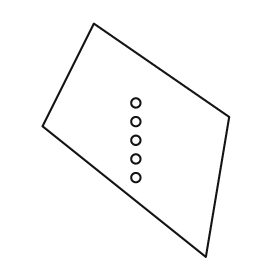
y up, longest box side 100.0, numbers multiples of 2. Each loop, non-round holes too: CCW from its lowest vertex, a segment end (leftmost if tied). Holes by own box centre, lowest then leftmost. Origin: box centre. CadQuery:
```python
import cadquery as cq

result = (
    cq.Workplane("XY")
    .moveTo(30.0, -50.0)
    .lineTo(40.0, 10.0)
    .lineTo(-18.0, 50.0)
    .lineTo(-40.0, 6.0)
    .close()
    .moveTo(0.0, -16.0)
    .circle(2.0)
    .moveTo(0.0, -8.0)
    .circle(2.0)
    .moveTo(0.0, 0.0)
    .circle(2.0)
    .moveTo(0.0, 8.0)
    .circle(2.0)
    .moveTo(0.0, 16.0)
    .circle(2.0)
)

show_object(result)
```